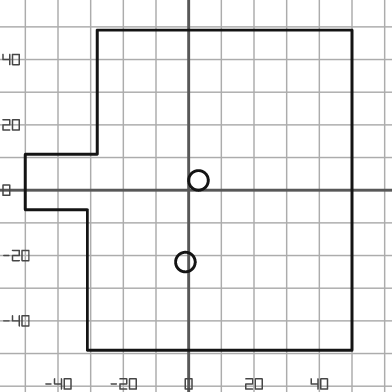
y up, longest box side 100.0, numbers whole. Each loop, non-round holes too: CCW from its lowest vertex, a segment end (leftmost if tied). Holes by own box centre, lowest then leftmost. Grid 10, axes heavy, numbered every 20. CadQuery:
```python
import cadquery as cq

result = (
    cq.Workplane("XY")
    .moveTo(-31.0, -49.0)
    .lineTo(50.0, -49.0)
    .lineTo(50.0, 49.0)
    .lineTo(-28.0, 49.0)
    .lineTo(-28.0, 11.0)
    .lineTo(-50.0, 11.0)
    .lineTo(-50.0, -6.0)
    .lineTo(-31.0, -6.0)
    .close()
    .moveTo(-1.0, -22.0)
    .circle(3.0)
    .moveTo(3.0, 3.0)
    .circle(3.0)
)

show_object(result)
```